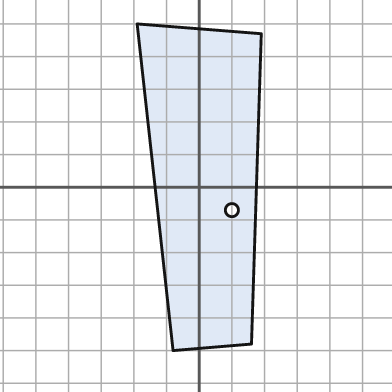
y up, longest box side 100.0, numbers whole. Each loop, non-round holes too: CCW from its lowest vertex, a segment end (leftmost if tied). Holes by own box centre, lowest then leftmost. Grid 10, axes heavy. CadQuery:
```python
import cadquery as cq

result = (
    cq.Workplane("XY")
    .moveTo(-8.0, -50.0)
    .lineTo(16.0, -48.0)
    .lineTo(19.0, 47.0)
    .lineTo(-19.0, 50.0)
    .close()
    .moveTo(10.0, -7.0)
    .circle(2.0)
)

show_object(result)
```